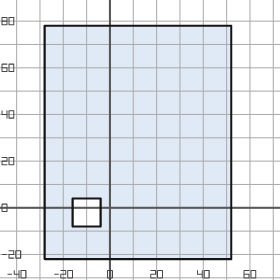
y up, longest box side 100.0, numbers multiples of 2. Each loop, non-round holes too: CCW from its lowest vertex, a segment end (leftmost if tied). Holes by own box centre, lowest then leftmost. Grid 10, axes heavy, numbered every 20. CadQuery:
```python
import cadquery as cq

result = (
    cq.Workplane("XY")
    .moveTo(-28.0, -22.0)
    .lineTo(52.0, -22.0)
    .lineTo(52.0, 78.0)
    .lineTo(-28.0, 78.0)
    .close()
    .moveTo(-16.0, -8.0)
    .lineTo(-4.0, -8.0)
    .lineTo(-4.0, 4.0)
    .lineTo(-16.0, 4.0)
    .close()
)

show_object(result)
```